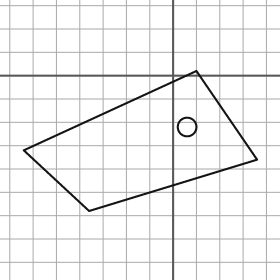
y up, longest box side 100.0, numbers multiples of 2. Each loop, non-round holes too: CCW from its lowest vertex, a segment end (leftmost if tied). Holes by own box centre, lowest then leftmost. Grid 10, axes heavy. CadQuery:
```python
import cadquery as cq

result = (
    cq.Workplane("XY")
    .moveTo(-36.0, -58.0)
    .lineTo(36.0, -36.0)
    .lineTo(10.0, 2.0)
    .lineTo(-64.0, -32.0)
    .close()
    .moveTo(6.0, -22.0)
    .circle(4.0)
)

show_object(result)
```